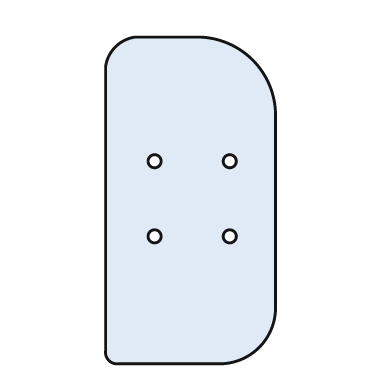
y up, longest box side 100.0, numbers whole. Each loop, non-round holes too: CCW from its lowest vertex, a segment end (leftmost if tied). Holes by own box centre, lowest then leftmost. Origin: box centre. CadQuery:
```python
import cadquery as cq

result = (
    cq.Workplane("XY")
    .moveTo(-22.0, -50.0)
    .lineTo(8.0, -50.0)
    .threePointArc((21.0, -45.0), (26.0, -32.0))
    .lineTo(26.0, 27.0)
    .threePointArc((19.0, 43.0), (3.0, 50.0))
    .lineTo(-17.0, 50.0)
    .threePointArc((-23.0, 47.0), (-26.0, 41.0))
    .lineTo(-26.0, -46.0)
    .threePointArc((-25.0, -49.0), (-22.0, -50.0))
    .close()
    .moveTo(-11.0, -11.0)
    .circle(2.0)
    .moveTo(12.0, -11.0)
    .circle(2.0)
    .moveTo(-11.0, 12.0)
    .circle(2.0)
    .moveTo(12.0, 12.0)
    .circle(2.0)
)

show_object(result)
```